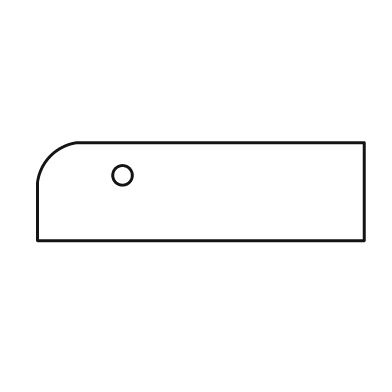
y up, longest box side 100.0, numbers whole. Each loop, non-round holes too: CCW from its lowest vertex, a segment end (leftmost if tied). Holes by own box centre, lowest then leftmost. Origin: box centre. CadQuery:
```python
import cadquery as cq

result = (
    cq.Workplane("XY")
    .moveTo(-50.0, -15.0)
    .lineTo(50.0, -15.0)
    .lineTo(50.0, 15.0)
    .lineTo(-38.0, 15.0)
    .threePointArc((-46.0, 11.0), (-50.0, 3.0))
    .close()
    .moveTo(-24.0, 5.0)
    .circle(3.0)
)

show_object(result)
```